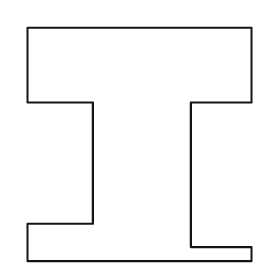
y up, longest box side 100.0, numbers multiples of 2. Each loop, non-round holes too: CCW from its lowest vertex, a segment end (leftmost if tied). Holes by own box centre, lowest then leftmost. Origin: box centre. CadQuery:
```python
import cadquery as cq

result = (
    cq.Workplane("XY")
    .moveTo(-48.0, -50.0)
    .lineTo(48.0, -50.0)
    .lineTo(48.0, -44.0)
    .lineTo(22.0, -44.0)
    .lineTo(22.0, 18.0)
    .lineTo(48.0, 18.0)
    .lineTo(48.0, 50.0)
    .lineTo(-48.0, 50.0)
    .lineTo(-48.0, 18.0)
    .lineTo(-20.0, 18.0)
    .lineTo(-20.0, -34.0)
    .lineTo(-48.0, -34.0)
    .close()
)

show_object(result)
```